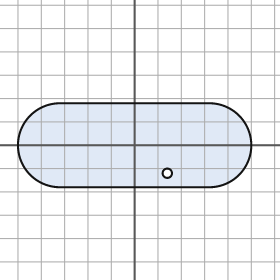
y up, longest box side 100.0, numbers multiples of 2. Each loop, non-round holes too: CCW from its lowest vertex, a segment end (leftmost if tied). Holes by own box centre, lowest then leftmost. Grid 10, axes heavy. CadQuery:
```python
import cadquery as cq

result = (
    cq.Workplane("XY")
    .moveTo(-32.0, -18.0)
    .lineTo(32.0, -18.0)
    .threePointArc((50.0, 0.0), (32.0, 18.0))
    .lineTo(-32.0, 18.0)
    .threePointArc((-50.0, 0.0), (-32.0, -18.0))
    .close()
    .moveTo(14.0, -12.0)
    .circle(2.0)
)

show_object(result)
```